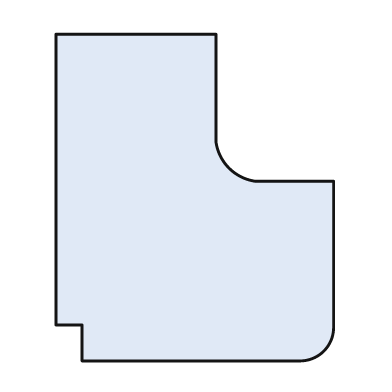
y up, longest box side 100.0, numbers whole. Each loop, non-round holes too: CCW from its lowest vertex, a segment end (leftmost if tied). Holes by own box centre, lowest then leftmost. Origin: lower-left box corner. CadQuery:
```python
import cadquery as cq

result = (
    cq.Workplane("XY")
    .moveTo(8.0, 0.0)
    .lineTo(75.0, 0.0)
    .threePointArc((82.0, 3.0), (85.0, 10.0))
    .lineTo(85.0, 55.0)
    .lineTo(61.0, 55.0)
    .threePointArc((53.0, 59.0), (49.0, 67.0))
    .lineTo(49.0, 100.0)
    .lineTo(0.0, 100.0)
    .lineTo(0.0, 11.0)
    .lineTo(8.0, 11.0)
    .close()
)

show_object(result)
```